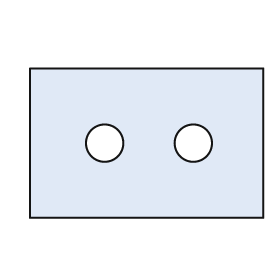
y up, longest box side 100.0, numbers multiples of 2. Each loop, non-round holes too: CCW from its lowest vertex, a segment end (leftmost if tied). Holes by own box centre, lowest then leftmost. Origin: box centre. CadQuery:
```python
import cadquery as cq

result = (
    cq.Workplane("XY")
    .moveTo(-50.0, -32.0)
    .lineTo(50.0, -32.0)
    .lineTo(50.0, 32.0)
    .lineTo(-50.0, 32.0)
    .close()
    .moveTo(-18.0, 0.0)
    .circle(8.0)
    .moveTo(20.0, 0.0)
    .circle(8.0)
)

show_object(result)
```